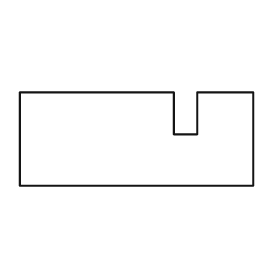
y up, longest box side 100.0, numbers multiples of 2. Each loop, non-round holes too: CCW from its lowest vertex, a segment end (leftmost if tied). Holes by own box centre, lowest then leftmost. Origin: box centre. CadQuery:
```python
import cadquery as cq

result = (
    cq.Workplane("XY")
    .moveTo(-50.0, -20.0)
    .lineTo(50.0, -20.0)
    .lineTo(50.0, 20.0)
    .lineTo(26.0, 20.0)
    .lineTo(26.0, 2.0)
    .lineTo(16.0, 2.0)
    .lineTo(16.0, 20.0)
    .lineTo(-50.0, 20.0)
    .close()
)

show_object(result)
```